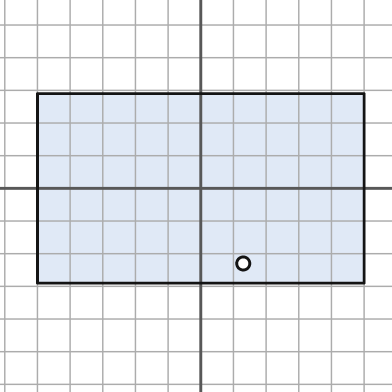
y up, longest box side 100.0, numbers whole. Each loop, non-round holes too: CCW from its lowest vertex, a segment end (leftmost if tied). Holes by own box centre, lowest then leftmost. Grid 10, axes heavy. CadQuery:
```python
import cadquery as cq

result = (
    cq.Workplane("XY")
    .moveTo(-50.0, -29.0)
    .lineTo(50.0, -29.0)
    .lineTo(50.0, 29.0)
    .lineTo(-50.0, 29.0)
    .close()
    .moveTo(13.0, -23.0)
    .circle(2.0)
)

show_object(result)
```